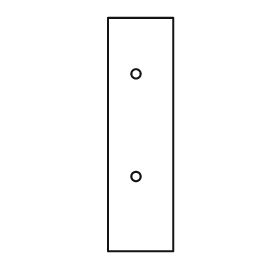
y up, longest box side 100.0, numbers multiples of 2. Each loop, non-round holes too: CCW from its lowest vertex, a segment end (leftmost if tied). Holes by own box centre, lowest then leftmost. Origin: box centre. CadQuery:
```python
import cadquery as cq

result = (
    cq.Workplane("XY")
    .moveTo(-14.0, -50.0)
    .lineTo(14.0, -50.0)
    .lineTo(14.0, 50.0)
    .lineTo(-14.0, 50.0)
    .close()
    .moveTo(-2.0, -18.0)
    .circle(2.0)
    .moveTo(-2.0, 26.0)
    .circle(2.0)
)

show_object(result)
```